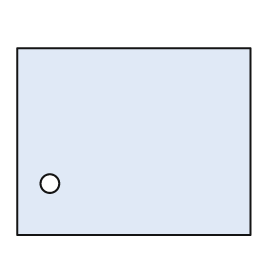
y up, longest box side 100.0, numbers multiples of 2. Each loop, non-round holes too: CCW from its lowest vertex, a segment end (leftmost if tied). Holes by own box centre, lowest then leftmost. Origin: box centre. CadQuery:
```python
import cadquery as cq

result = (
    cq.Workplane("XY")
    .moveTo(-50.0, -40.0)
    .lineTo(50.0, -40.0)
    .lineTo(50.0, 40.0)
    .lineTo(-50.0, 40.0)
    .close()
    .moveTo(-36.0, -18.0)
    .circle(4.0)
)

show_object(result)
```